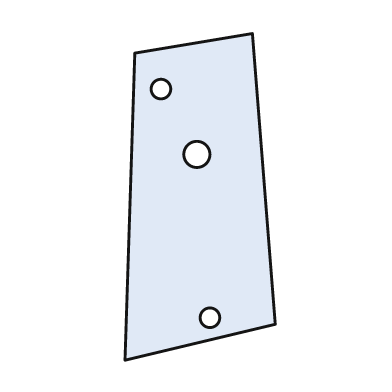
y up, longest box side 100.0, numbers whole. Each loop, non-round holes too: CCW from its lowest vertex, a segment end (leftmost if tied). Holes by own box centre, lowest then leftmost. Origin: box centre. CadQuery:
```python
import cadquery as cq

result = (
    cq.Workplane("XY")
    .moveTo(-23.0, -50.0)
    .lineTo(23.0, -39.0)
    .lineTo(16.0, 50.0)
    .lineTo(-20.0, 44.0)
    .close()
    .moveTo(3.0, -37.0)
    .circle(3.0)
    .moveTo(-1.0, 13.0)
    .circle(4.0)
    .moveTo(-12.0, 33.0)
    .circle(3.0)
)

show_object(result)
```